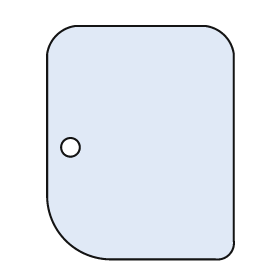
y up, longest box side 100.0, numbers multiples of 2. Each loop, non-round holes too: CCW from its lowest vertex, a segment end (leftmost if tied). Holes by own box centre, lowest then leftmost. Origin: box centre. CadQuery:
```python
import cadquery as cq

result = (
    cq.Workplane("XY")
    .moveTo(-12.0, -50.0)
    .lineTo(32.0, -50.0)
    .threePointArc((38.0, -48.0), (40.0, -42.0))
    .lineTo(40.0, 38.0)
    .threePointArc((36.0, 46.0), (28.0, 50.0))
    .lineTo(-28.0, 50.0)
    .threePointArc((-36.0, 46.0), (-40.0, 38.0))
    .lineTo(-40.0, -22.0)
    .threePointArc((-32.0, -42.0), (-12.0, -50.0))
    .close()
    .moveTo(-30.0, -2.0)
    .circle(4.0)
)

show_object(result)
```